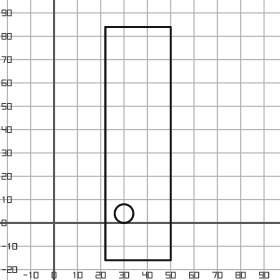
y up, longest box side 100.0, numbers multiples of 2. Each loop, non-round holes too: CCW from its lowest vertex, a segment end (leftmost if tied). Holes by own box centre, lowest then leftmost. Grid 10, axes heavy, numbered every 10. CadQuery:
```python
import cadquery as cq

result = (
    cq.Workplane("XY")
    .moveTo(22.0, -16.0)
    .lineTo(50.0, -16.0)
    .lineTo(50.0, 84.0)
    .lineTo(22.0, 84.0)
    .close()
    .moveTo(30.0, 4.0)
    .circle(4.0)
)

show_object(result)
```